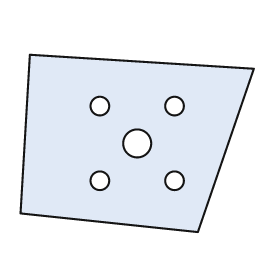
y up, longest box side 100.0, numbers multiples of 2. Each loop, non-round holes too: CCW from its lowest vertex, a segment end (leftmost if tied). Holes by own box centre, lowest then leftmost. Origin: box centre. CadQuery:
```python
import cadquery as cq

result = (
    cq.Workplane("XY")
    .moveTo(26.0, -38.0)
    .lineTo(50.0, 32.0)
    .lineTo(-46.0, 38.0)
    .lineTo(-50.0, -30.0)
    .close()
    .moveTo(-16.0, -16.0)
    .circle(4.0)
    .moveTo(16.0, -16.0)
    .circle(4.0)
    .moveTo(0.0, 0.0)
    .circle(6.0)
    .moveTo(-16.0, 16.0)
    .circle(4.0)
    .moveTo(16.0, 16.0)
    .circle(4.0)
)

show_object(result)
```